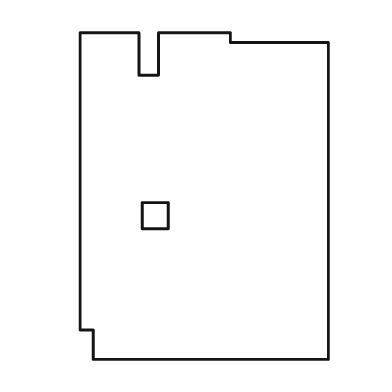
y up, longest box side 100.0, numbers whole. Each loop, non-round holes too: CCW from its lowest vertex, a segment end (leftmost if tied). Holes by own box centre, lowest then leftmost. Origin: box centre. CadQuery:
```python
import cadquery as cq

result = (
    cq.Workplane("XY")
    .moveTo(-34.0, -50.0)
    .lineTo(38.0, -50.0)
    .lineTo(38.0, 47.0)
    .lineTo(8.0, 47.0)
    .lineTo(8.0, 50.0)
    .lineTo(-14.0, 50.0)
    .lineTo(-14.0, 37.0)
    .lineTo(-20.0, 37.0)
    .lineTo(-20.0, 50.0)
    .lineTo(-38.0, 50.0)
    .lineTo(-38.0, -41.0)
    .lineTo(-34.0, -41.0)
    .close()
    .moveTo(-19.0, -10.0)
    .lineTo(-11.0, -10.0)
    .lineTo(-11.0, -2.0)
    .lineTo(-19.0, -2.0)
    .close()
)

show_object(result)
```